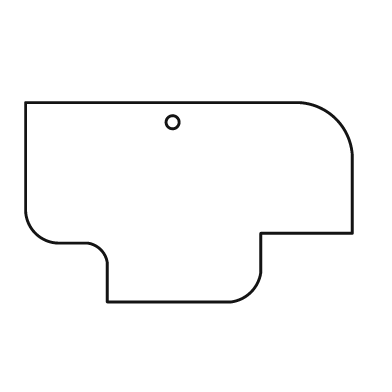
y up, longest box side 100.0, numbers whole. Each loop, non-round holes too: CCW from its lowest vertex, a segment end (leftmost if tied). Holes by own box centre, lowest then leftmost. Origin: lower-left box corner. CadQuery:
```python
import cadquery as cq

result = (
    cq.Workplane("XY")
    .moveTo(25.0, 0.0)
    .lineTo(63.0, 0.0)
    .threePointArc((69.0, 3.0), (72.0, 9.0))
    .lineTo(72.0, 21.0)
    .lineTo(100.0, 21.0)
    .lineTo(100.0, 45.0)
    .threePointArc((95.0, 56.0), (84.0, 61.0))
    .lineTo(0.0, 61.0)
    .lineTo(0.0, 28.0)
    .threePointArc((3.0, 21.0), (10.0, 18.0))
    .lineTo(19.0, 18.0)
    .threePointArc((23.0, 16.0), (25.0, 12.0))
    .close()
    .moveTo(45.0, 55.0)
    .circle(2.0)
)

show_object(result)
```